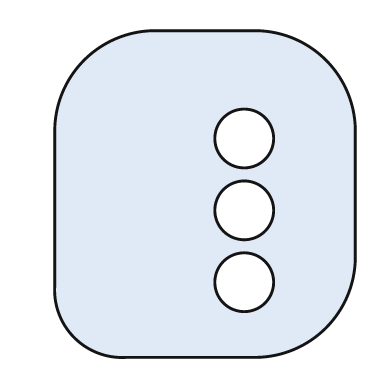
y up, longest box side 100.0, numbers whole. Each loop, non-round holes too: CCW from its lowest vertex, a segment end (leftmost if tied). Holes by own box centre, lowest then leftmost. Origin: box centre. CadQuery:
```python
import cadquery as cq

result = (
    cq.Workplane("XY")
    .moveTo(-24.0, -50.0)
    .lineTo(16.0, -50.0)
    .threePointArc((37.0, -41.0), (46.0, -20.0))
    .lineTo(46.0, 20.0)
    .threePointArc((37.0, 41.0), (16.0, 50.0))
    .lineTo(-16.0, 50.0)
    .threePointArc((-37.0, 41.0), (-46.0, 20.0))
    .lineTo(-46.0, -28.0)
    .threePointArc((-40.0, -44.0), (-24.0, -50.0))
    .close()
    .moveTo(12.0, -27.0)
    .circle(9.0)
    .moveTo(12.0, -5.0)
    .circle(9.0)
    .moveTo(12.0, 17.0)
    .circle(9.0)
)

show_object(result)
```